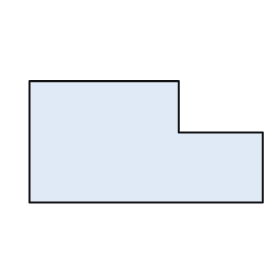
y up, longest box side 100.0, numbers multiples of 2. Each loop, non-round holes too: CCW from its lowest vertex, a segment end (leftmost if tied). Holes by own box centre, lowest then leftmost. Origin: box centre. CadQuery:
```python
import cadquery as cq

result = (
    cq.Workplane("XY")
    .moveTo(-50.0, -26.0)
    .lineTo(50.0, -26.0)
    .lineTo(50.0, 4.0)
    .lineTo(14.0, 4.0)
    .lineTo(14.0, 26.0)
    .lineTo(-50.0, 26.0)
    .close()
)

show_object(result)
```